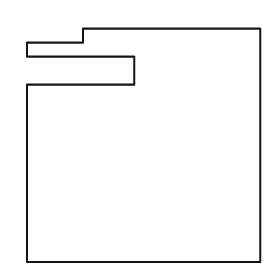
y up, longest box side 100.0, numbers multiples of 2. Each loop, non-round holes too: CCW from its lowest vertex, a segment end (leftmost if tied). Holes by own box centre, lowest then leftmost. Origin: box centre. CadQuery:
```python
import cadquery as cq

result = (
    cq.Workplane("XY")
    .moveTo(-50.0, -50.0)
    .lineTo(50.0, -50.0)
    .lineTo(50.0, 50.0)
    .lineTo(-26.0, 50.0)
    .lineTo(-26.0, 44.0)
    .lineTo(-50.0, 44.0)
    .lineTo(-50.0, 38.0)
    .lineTo(-4.0, 38.0)
    .lineTo(-4.0, 26.0)
    .lineTo(-50.0, 26.0)
    .close()
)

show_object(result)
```